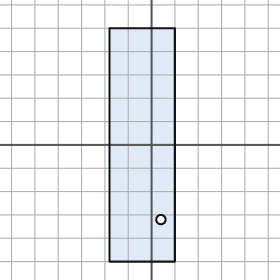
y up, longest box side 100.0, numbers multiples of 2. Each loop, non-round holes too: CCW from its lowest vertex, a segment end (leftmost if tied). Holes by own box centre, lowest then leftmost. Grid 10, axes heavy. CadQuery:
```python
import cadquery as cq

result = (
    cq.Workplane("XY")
    .moveTo(-18.0, -50.0)
    .lineTo(10.0, -50.0)
    .lineTo(10.0, 50.0)
    .lineTo(-18.0, 50.0)
    .close()
    .moveTo(4.0, -32.0)
    .circle(2.0)
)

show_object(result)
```